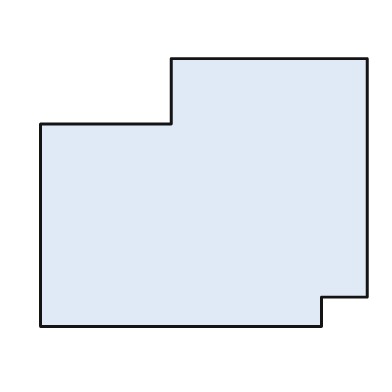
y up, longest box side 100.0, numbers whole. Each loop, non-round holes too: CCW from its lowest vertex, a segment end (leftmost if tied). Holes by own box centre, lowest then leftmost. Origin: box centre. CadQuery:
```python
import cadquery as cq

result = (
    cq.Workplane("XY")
    .moveTo(-50.0, -41.0)
    .lineTo(36.0, -41.0)
    .lineTo(36.0, -32.0)
    .lineTo(50.0, -32.0)
    .lineTo(50.0, 41.0)
    .lineTo(-10.0, 41.0)
    .lineTo(-10.0, 21.0)
    .lineTo(-50.0, 21.0)
    .close()
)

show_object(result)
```